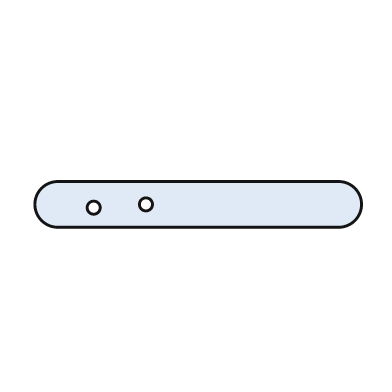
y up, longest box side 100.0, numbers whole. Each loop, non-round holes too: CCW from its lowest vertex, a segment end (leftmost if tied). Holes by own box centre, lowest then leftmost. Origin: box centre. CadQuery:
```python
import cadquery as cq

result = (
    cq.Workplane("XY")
    .moveTo(-43.0, -7.0)
    .lineTo(43.0, -7.0)
    .threePointArc((50.0, 0.0), (43.0, 7.0))
    .lineTo(-43.0, 7.0)
    .threePointArc((-50.0, 0.0), (-43.0, -7.0))
    .close()
    .moveTo(-32.0, -1.0)
    .circle(2.0)
    .moveTo(-16.0, 0.0)
    .circle(2.0)
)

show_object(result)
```